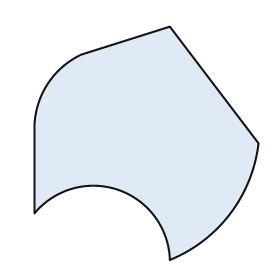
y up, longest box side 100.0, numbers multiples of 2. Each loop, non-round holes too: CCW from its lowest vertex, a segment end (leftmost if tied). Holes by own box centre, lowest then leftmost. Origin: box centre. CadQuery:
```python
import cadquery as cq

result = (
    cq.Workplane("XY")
    .moveTo(10.0, -50.0)
    .threePointArc((36.0, -30.0), (48.0, 0.0))
    .lineTo(10.0, 50.0)
    .lineTo(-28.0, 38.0)
    .threePointArc((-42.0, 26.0), (-48.0, 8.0))
    .lineTo(-48.0, -30.0)
    .threePointArc((-12.0, -20.0), (10.0, -50.0))
    .close()
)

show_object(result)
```